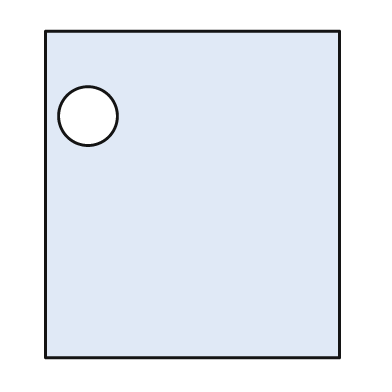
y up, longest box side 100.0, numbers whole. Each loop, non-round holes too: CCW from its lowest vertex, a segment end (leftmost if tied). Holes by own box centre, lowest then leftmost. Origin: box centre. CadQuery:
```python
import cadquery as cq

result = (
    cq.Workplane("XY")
    .moveTo(-45.0, -50.0)
    .lineTo(45.0, -50.0)
    .lineTo(45.0, 50.0)
    .lineTo(-45.0, 50.0)
    .close()
    .moveTo(-32.0, 24.0)
    .circle(9.0)
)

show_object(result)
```